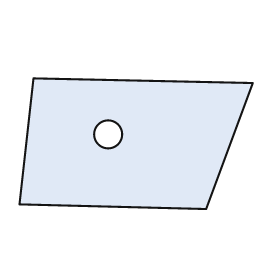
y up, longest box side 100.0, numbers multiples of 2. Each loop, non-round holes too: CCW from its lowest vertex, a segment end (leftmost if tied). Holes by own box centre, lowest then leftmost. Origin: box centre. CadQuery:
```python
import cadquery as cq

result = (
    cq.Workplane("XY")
    .moveTo(30.0, -28.0)
    .lineTo(50.0, 26.0)
    .lineTo(-44.0, 28.0)
    .lineTo(-50.0, -26.0)
    .close()
    .moveTo(-12.0, 4.0)
    .circle(6.0)
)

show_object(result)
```